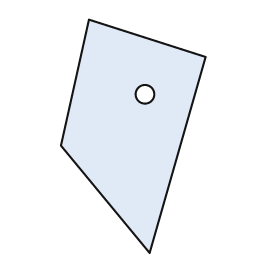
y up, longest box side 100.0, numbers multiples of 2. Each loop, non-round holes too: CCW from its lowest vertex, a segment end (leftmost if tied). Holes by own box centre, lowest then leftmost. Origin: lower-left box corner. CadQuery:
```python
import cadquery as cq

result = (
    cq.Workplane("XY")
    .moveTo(38.0, 0.0)
    .lineTo(62.0, 84.0)
    .lineTo(12.0, 100.0)
    .lineTo(0.0, 46.0)
    .close()
    .moveTo(36.0, 68.0)
    .circle(4.0)
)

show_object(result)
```